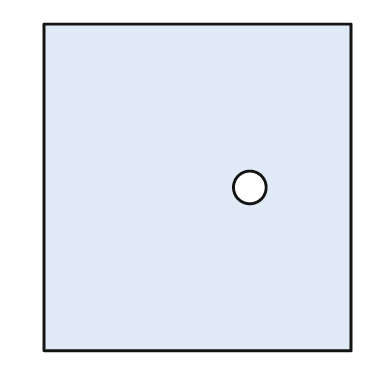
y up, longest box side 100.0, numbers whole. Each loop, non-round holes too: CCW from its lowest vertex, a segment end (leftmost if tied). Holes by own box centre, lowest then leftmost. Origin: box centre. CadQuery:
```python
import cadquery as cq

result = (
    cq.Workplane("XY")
    .moveTo(-47.0, -50.0)
    .lineTo(47.0, -50.0)
    .lineTo(47.0, 50.0)
    .lineTo(-47.0, 50.0)
    .close()
    .moveTo(16.0, 0.0)
    .circle(5.0)
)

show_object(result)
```